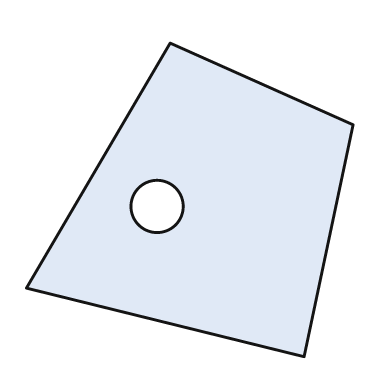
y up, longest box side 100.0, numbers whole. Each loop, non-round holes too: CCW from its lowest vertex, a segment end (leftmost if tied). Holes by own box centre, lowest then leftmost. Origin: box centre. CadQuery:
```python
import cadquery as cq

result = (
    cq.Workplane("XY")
    .moveTo(35.0, -48.0)
    .lineTo(50.0, 23.0)
    .lineTo(-6.0, 48.0)
    .lineTo(-50.0, -27.0)
    .close()
    .moveTo(-10.0, -2.0)
    .circle(8.0)
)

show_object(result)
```